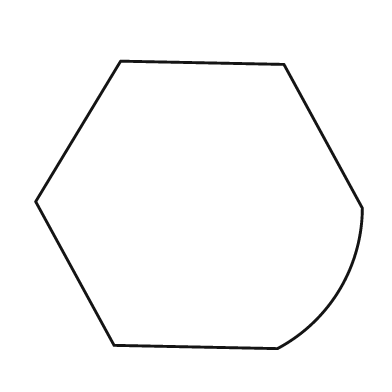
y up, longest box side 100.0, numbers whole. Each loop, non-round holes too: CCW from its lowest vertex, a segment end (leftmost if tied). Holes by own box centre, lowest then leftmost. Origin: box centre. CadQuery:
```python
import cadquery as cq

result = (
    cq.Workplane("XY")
    .moveTo(24.0, -44.0)
    .threePointArc((43.0, -26.0), (50.0, -1.0))
    .lineTo(26.0, 43.0)
    .lineTo(-24.0, 44.0)
    .lineTo(-50.0, 1.0)
    .lineTo(-26.0, -43.0)
    .close()
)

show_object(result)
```